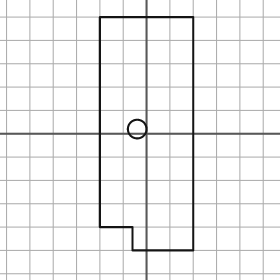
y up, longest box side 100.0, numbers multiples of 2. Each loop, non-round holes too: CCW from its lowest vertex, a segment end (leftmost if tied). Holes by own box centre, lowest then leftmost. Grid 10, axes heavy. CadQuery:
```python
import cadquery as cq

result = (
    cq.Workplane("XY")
    .moveTo(-6.0, -50.0)
    .lineTo(20.0, -50.0)
    .lineTo(20.0, 50.0)
    .lineTo(-20.0, 50.0)
    .lineTo(-20.0, -40.0)
    .lineTo(-6.0, -40.0)
    .close()
    .moveTo(-4.0, 2.0)
    .circle(4.0)
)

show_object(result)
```